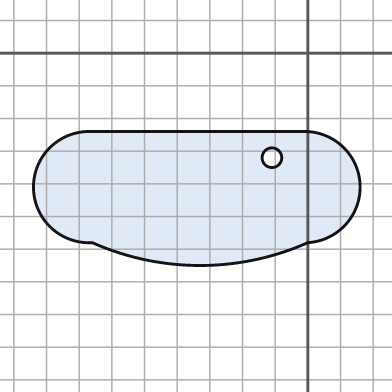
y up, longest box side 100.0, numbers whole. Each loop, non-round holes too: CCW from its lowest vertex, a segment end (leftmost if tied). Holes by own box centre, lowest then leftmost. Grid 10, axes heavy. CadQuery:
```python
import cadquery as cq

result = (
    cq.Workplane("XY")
    .moveTo(-66.0, -58.0)
    .threePointArc((-33.0, -65.0), (0.0, -58.0))
    .threePointArc((16.0, -41.0), (0.0, -24.0))
    .lineTo(-66.0, -24.0)
    .threePointArc((-84.0, -41.0), (-66.0, -58.0))
    .close()
    .moveTo(-11.0, -32.0)
    .circle(3.0)
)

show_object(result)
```